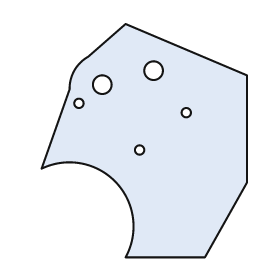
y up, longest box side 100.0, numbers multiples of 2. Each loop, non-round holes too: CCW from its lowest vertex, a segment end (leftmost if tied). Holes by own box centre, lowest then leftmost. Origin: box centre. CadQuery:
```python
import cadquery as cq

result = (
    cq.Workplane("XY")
    .moveTo(-8.0, -50.0)
    .lineTo(26.0, -50.0)
    .lineTo(44.0, -18.0)
    .lineTo(44.0, 28.0)
    .lineTo(-8.0, 50.0)
    .lineTo(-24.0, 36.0)
    .threePointArc((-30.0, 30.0), (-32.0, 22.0))
    .lineTo(-44.0, -12.0)
    .threePointArc((-12.0, -18.0), (-8.0, -50.0))
    .close()
    .moveTo(-2.0, -4.0)
    .circle(2.0)
    .moveTo(18.0, 12.0)
    .circle(2.0)
    .moveTo(-28.0, 16.0)
    .circle(2.0)
    .moveTo(-18.0, 24.0)
    .circle(4.0)
    .moveTo(4.0, 30.0)
    .circle(4.0)
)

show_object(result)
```